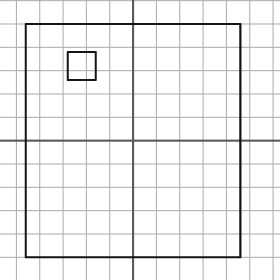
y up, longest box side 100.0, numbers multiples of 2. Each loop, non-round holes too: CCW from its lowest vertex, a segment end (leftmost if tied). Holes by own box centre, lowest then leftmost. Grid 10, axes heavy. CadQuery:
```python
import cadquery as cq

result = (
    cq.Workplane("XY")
    .moveTo(-46.0, -50.0)
    .lineTo(46.0, -50.0)
    .lineTo(46.0, 50.0)
    .lineTo(-46.0, 50.0)
    .close()
    .moveTo(-28.0, 26.0)
    .lineTo(-16.0, 26.0)
    .lineTo(-16.0, 38.0)
    .lineTo(-28.0, 38.0)
    .close()
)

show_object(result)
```